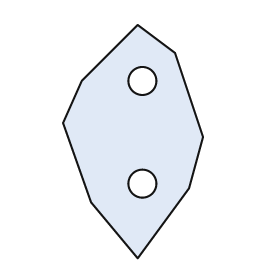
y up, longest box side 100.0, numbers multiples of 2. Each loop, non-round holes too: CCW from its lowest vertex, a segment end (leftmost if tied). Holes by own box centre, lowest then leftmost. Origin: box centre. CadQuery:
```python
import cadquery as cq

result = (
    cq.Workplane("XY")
    .moveTo(2.0, -50.0)
    .lineTo(24.0, -20.0)
    .lineTo(30.0, 2.0)
    .lineTo(18.0, 38.0)
    .lineTo(2.0, 50.0)
    .lineTo(-22.0, 26.0)
    .lineTo(-30.0, 8.0)
    .lineTo(-18.0, -26.0)
    .close()
    .moveTo(4.0, -18.0)
    .circle(6.0)
    .moveTo(4.0, 26.0)
    .circle(6.0)
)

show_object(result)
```